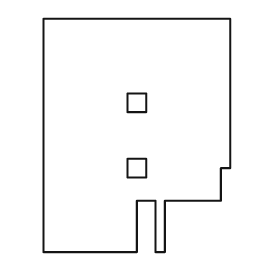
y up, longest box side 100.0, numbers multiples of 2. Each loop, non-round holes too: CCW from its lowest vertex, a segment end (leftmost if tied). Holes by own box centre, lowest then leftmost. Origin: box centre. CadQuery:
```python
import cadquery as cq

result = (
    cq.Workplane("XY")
    .moveTo(-40.0, -50.0)
    .lineTo(0.0, -50.0)
    .lineTo(0.0, -28.0)
    .lineTo(8.0, -28.0)
    .lineTo(8.0, -50.0)
    .lineTo(12.0, -50.0)
    .lineTo(12.0, -28.0)
    .lineTo(36.0, -28.0)
    .lineTo(36.0, -14.0)
    .lineTo(40.0, -14.0)
    .lineTo(40.0, 50.0)
    .lineTo(-40.0, 50.0)
    .close()
    .moveTo(-4.0, -18.0)
    .lineTo(4.0, -18.0)
    .lineTo(4.0, -10.0)
    .lineTo(-4.0, -10.0)
    .close()
    .moveTo(-4.0, 10.0)
    .lineTo(4.0, 10.0)
    .lineTo(4.0, 18.0)
    .lineTo(-4.0, 18.0)
    .close()
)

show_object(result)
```